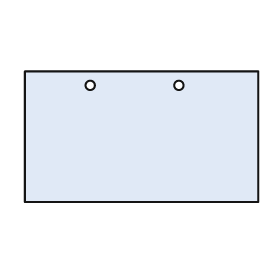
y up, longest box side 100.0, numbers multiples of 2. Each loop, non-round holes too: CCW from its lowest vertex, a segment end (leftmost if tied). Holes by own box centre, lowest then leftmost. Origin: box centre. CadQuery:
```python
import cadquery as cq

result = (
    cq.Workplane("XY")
    .moveTo(-50.0, -28.0)
    .lineTo(50.0, -28.0)
    .lineTo(50.0, 28.0)
    .lineTo(-50.0, 28.0)
    .close()
    .moveTo(-22.0, 22.0)
    .circle(2.0)
    .moveTo(16.0, 22.0)
    .circle(2.0)
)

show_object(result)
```